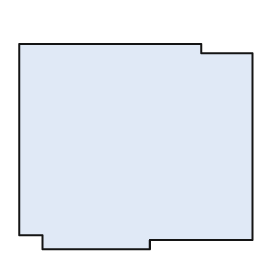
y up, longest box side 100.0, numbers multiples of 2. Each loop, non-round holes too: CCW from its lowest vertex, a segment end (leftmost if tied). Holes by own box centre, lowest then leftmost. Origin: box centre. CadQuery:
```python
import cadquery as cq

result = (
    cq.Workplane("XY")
    .moveTo(-40.0, -44.0)
    .lineTo(6.0, -44.0)
    .lineTo(6.0, -40.0)
    .lineTo(50.0, -40.0)
    .lineTo(50.0, 40.0)
    .lineTo(28.0, 40.0)
    .lineTo(28.0, 44.0)
    .lineTo(-50.0, 44.0)
    .lineTo(-50.0, -38.0)
    .lineTo(-40.0, -38.0)
    .close()
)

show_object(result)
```